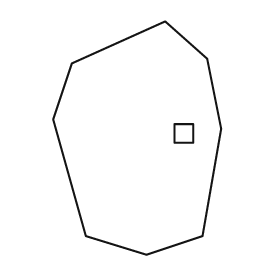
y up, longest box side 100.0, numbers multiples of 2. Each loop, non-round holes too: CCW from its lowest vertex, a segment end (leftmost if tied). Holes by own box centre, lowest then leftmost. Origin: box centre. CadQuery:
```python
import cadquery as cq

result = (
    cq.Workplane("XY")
    .moveTo(4.0, -50.0)
    .lineTo(28.0, -42.0)
    .lineTo(36.0, 4.0)
    .lineTo(30.0, 34.0)
    .lineTo(12.0, 50.0)
    .lineTo(-28.0, 32.0)
    .lineTo(-36.0, 8.0)
    .lineTo(-22.0, -42.0)
    .close()
    .moveTo(16.0, -2.0)
    .lineTo(24.0, -2.0)
    .lineTo(24.0, 6.0)
    .lineTo(16.0, 6.0)
    .close()
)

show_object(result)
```